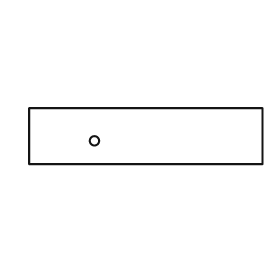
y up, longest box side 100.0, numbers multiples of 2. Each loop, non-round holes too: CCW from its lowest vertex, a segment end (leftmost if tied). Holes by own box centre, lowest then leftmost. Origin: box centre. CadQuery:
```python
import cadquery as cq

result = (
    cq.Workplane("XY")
    .moveTo(-50.0, -12.0)
    .lineTo(50.0, -12.0)
    .lineTo(50.0, 12.0)
    .lineTo(-50.0, 12.0)
    .close()
    .moveTo(-22.0, -2.0)
    .circle(2.0)
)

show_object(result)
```